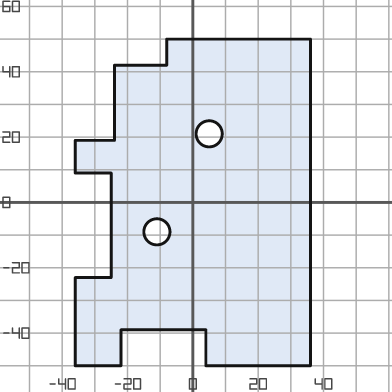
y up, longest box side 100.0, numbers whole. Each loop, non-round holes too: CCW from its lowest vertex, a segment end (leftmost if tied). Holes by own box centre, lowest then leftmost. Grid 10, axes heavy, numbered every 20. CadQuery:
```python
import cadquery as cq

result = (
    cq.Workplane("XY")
    .moveTo(-36.0, -50.0)
    .lineTo(-22.0, -50.0)
    .lineTo(-22.0, -39.0)
    .lineTo(4.0, -39.0)
    .lineTo(4.0, -50.0)
    .lineTo(36.0, -50.0)
    .lineTo(36.0, 50.0)
    .lineTo(-8.0, 50.0)
    .lineTo(-8.0, 42.0)
    .lineTo(-24.0, 42.0)
    .lineTo(-24.0, 19.0)
    .lineTo(-36.0, 19.0)
    .lineTo(-36.0, 9.0)
    .lineTo(-25.0, 9.0)
    .lineTo(-25.0, -23.0)
    .lineTo(-36.0, -23.0)
    .close()
    .moveTo(-11.0, -9.0)
    .circle(4.0)
    .moveTo(5.0, 21.0)
    .circle(4.0)
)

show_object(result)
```